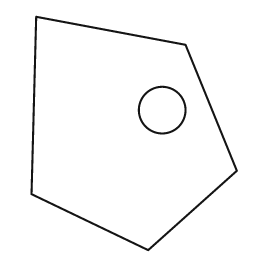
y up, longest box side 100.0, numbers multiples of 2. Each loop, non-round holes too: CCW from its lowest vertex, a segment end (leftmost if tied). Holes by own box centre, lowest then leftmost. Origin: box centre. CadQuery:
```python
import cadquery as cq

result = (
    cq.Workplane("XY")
    .moveTo(6.0, -50.0)
    .lineTo(44.0, -16.0)
    .lineTo(22.0, 38.0)
    .lineTo(-42.0, 50.0)
    .lineTo(-44.0, -26.0)
    .close()
    .moveTo(12.0, 10.0)
    .circle(10.0)
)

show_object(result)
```